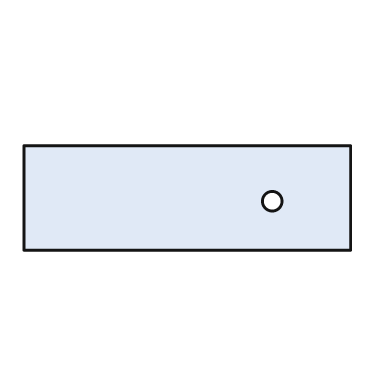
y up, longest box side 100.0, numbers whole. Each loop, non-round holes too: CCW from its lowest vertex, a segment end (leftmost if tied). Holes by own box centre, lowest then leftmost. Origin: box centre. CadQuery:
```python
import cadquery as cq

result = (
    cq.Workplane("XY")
    .moveTo(-50.0, -16.0)
    .lineTo(50.0, -16.0)
    .lineTo(50.0, 16.0)
    .lineTo(-50.0, 16.0)
    .close()
    .moveTo(26.0, -1.0)
    .circle(3.0)
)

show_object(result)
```